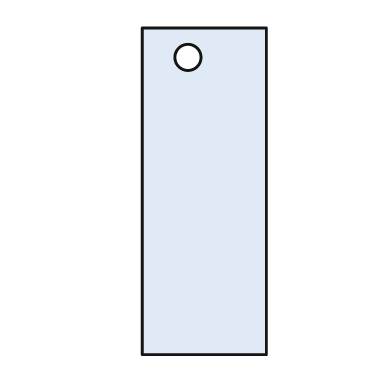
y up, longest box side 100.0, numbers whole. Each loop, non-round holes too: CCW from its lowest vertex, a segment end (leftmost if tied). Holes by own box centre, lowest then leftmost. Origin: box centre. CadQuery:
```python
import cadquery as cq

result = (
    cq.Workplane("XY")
    .moveTo(-19.0, -50.0)
    .lineTo(19.0, -50.0)
    .lineTo(19.0, 50.0)
    .lineTo(-19.0, 50.0)
    .close()
    .moveTo(-5.0, 41.0)
    .circle(4.0)
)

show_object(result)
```